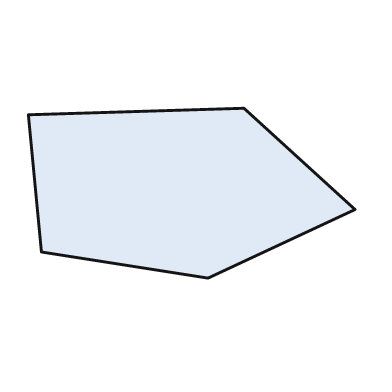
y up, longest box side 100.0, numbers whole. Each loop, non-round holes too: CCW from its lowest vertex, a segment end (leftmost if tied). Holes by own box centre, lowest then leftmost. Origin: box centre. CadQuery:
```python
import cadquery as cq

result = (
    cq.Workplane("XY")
    .moveTo(5.0, -26.0)
    .lineTo(50.0, -5.0)
    .lineTo(16.0, 26.0)
    .lineTo(-50.0, 24.0)
    .lineTo(-46.0, -18.0)
    .close()
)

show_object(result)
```